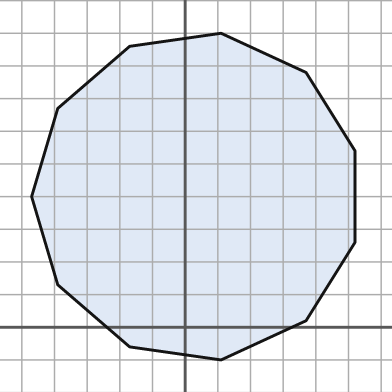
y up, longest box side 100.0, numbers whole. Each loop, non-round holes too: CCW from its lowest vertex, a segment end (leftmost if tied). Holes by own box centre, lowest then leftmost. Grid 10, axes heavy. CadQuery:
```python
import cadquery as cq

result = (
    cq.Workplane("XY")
    .moveTo(11.0, -10.0)
    .lineTo(37.0, 2.0)
    .lineTo(52.0, 26.0)
    .lineTo(52.0, 54.0)
    .lineTo(37.0, 78.0)
    .lineTo(11.0, 90.0)
    .lineTo(-17.0, 86.0)
    .lineTo(-39.0, 67.0)
    .lineTo(-47.0, 40.0)
    .lineTo(-39.0, 13.0)
    .lineTo(-17.0, -6.0)
    .close()
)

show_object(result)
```